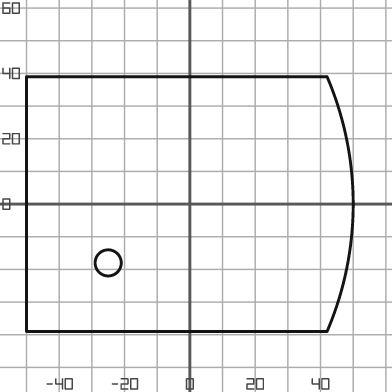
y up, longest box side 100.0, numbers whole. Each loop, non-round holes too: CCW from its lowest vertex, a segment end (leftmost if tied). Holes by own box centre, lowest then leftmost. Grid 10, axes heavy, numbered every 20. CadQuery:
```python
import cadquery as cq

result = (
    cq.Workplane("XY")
    .moveTo(-50.0, -39.0)
    .lineTo(42.0, -39.0)
    .threePointArc((50.0, 0.0), (42.0, 39.0))
    .lineTo(-50.0, 39.0)
    .close()
    .moveTo(-25.0, -18.0)
    .circle(4.0)
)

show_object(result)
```